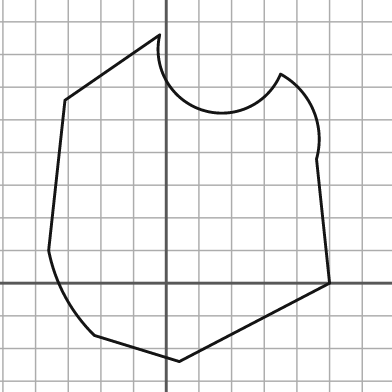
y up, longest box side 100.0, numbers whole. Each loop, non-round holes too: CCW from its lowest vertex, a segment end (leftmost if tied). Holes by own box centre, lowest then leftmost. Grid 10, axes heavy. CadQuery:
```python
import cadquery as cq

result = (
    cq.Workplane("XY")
    .moveTo(4.0, -24.0)
    .lineTo(50.0, 0.0)
    .lineTo(46.0, 38.0)
    .threePointArc((45.0, 53.0), (35.0, 64.0))
    .threePointArc((11.0, 53.0), (-2.0, 76.0))
    .lineTo(-31.0, 56.0)
    .lineTo(-36.0, 10.0)
    .threePointArc((-31.0, -4.0), (-22.0, -16.0))
    .close()
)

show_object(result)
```